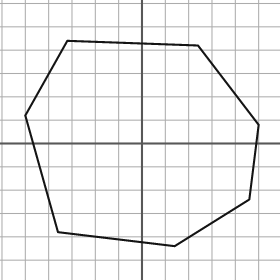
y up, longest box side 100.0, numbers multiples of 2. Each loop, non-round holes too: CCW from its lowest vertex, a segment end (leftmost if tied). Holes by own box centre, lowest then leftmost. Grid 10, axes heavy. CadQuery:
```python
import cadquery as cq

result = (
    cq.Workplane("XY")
    .moveTo(14.0, -44.0)
    .lineTo(46.0, -24.0)
    .lineTo(50.0, 8.0)
    .lineTo(24.0, 42.0)
    .lineTo(-32.0, 44.0)
    .lineTo(-50.0, 12.0)
    .lineTo(-36.0, -38.0)
    .close()
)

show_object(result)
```